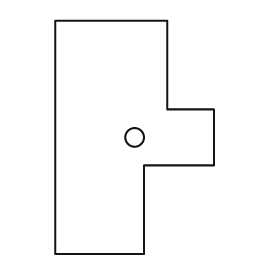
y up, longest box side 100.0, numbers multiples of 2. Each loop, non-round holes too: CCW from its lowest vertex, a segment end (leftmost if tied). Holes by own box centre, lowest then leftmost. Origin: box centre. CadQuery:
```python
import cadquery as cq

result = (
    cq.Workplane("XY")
    .moveTo(-34.0, -50.0)
    .lineTo(4.0, -50.0)
    .lineTo(4.0, -12.0)
    .lineTo(34.0, -12.0)
    .lineTo(34.0, 12.0)
    .lineTo(14.0, 12.0)
    .lineTo(14.0, 50.0)
    .lineTo(-34.0, 50.0)
    .close()
    .moveTo(0.0, 0.0)
    .circle(4.0)
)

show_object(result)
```